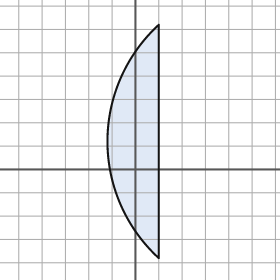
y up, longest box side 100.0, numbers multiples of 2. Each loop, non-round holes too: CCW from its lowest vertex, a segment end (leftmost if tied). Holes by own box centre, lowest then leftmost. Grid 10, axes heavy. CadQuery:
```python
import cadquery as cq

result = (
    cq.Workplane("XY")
    .moveTo(10.0, -38.0)
    .lineTo(10.0, 62.0)
    .threePointArc((-12.0, 12.0), (10.0, -38.0))
    .close()
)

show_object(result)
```